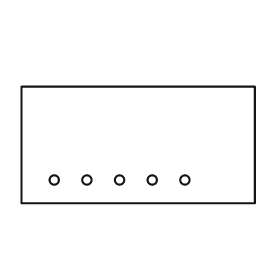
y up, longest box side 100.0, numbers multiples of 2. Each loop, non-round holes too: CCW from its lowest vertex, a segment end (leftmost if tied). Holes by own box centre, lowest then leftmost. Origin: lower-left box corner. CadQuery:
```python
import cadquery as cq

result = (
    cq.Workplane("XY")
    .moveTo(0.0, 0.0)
    .lineTo(100.0, 0.0)
    .lineTo(100.0, 50.0)
    .lineTo(0.0, 50.0)
    .close()
    .moveTo(14.0, 10.0)
    .circle(2.0)
    .moveTo(28.0, 10.0)
    .circle(2.0)
    .moveTo(42.0, 10.0)
    .circle(2.0)
    .moveTo(56.0, 10.0)
    .circle(2.0)
    .moveTo(70.0, 10.0)
    .circle(2.0)
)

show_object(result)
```